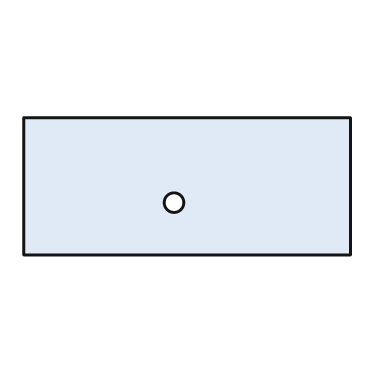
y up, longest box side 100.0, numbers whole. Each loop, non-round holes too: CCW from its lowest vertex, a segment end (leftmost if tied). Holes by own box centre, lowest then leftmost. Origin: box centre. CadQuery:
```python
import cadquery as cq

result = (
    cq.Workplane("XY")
    .moveTo(-50.0, -21.0)
    .lineTo(50.0, -21.0)
    .lineTo(50.0, 21.0)
    .lineTo(-50.0, 21.0)
    .close()
    .moveTo(-4.0, -5.0)
    .circle(3.0)
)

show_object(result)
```